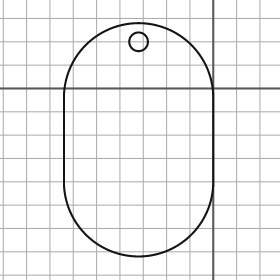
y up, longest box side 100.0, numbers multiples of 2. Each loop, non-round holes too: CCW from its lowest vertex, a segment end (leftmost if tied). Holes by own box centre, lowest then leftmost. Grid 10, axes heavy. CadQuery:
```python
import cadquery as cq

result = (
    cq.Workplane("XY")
    .moveTo(-64.0, -40.0)
    .threePointArc((-32.0, -72.0), (0.0, -40.0))
    .lineTo(0.0, -4.0)
    .threePointArc((-32.0, 28.0), (-64.0, -4.0))
    .close()
    .moveTo(-32.0, 20.0)
    .circle(4.0)
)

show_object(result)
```